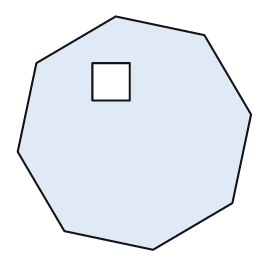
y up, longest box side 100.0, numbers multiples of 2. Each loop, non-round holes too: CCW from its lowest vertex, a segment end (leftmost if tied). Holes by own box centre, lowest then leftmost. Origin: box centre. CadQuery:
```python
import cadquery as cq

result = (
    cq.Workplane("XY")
    .moveTo(8.0, -50.0)
    .lineTo(42.0, -30.0)
    .lineTo(50.0, 8.0)
    .lineTo(30.0, 42.0)
    .lineTo(-8.0, 50.0)
    .lineTo(-42.0, 30.0)
    .lineTo(-50.0, -8.0)
    .lineTo(-30.0, -42.0)
    .close()
    .moveTo(-18.0, 14.0)
    .lineTo(-2.0, 14.0)
    .lineTo(-2.0, 30.0)
    .lineTo(-18.0, 30.0)
    .close()
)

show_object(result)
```